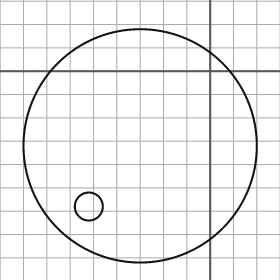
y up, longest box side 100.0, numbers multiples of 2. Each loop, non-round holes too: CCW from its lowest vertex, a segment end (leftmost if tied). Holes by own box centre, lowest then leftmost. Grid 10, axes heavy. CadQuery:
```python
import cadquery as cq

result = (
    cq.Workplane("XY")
    .moveTo(-30.0, -32.0)
    .circle(50.0)
    .moveTo(-52.0, -58.0)
    .circle(6.0)
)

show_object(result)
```